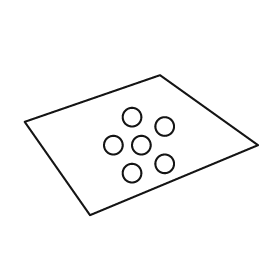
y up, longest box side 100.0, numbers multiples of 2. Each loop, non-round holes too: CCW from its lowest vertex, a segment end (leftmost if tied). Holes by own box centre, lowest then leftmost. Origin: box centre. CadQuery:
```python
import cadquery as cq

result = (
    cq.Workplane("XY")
    .moveTo(-22.0, -30.0)
    .lineTo(50.0, 0.0)
    .lineTo(8.0, 30.0)
    .lineTo(-50.0, 10.0)
    .close()
    .moveTo(-4.0, -12.0)
    .circle(4.0)
    .moveTo(10.0, -8.0)
    .circle(4.0)
    .moveTo(-12.0, 0.0)
    .circle(4.0)
    .moveTo(0.0, 0.0)
    .circle(4.0)
    .moveTo(10.0, 8.0)
    .circle(4.0)
    .moveTo(-4.0, 12.0)
    .circle(4.0)
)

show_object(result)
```